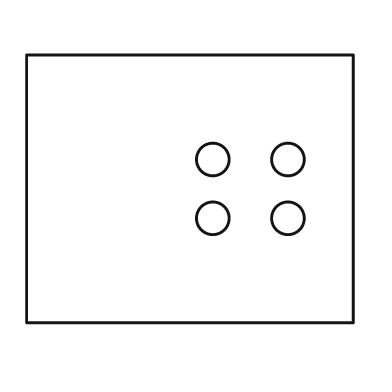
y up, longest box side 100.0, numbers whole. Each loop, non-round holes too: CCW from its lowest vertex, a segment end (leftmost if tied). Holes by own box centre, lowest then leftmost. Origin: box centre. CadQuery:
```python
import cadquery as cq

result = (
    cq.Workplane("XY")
    .moveTo(-50.0, -41.0)
    .lineTo(50.0, -41.0)
    .lineTo(50.0, 41.0)
    .lineTo(-50.0, 41.0)
    .close()
    .moveTo(7.0, -9.0)
    .circle(5.0)
    .moveTo(30.0, -9.0)
    .circle(5.0)
    .moveTo(7.0, 9.0)
    .circle(5.0)
    .moveTo(30.0, 9.0)
    .circle(5.0)
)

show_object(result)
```